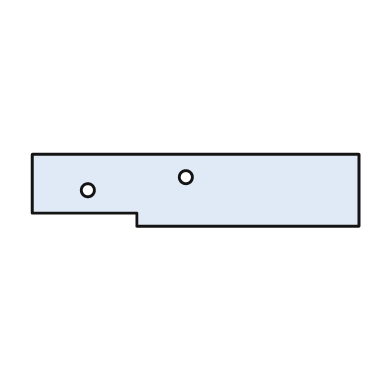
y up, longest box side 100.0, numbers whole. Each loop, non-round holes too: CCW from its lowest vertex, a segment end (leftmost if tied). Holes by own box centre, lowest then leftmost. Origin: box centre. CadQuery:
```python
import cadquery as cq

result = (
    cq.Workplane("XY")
    .moveTo(-18.0, -11.0)
    .lineTo(50.0, -11.0)
    .lineTo(50.0, 11.0)
    .lineTo(-50.0, 11.0)
    .lineTo(-50.0, -7.0)
    .lineTo(-18.0, -7.0)
    .close()
    .moveTo(-33.0, 0.0)
    .circle(2.0)
    .moveTo(-3.0, 4.0)
    .circle(2.0)
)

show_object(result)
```